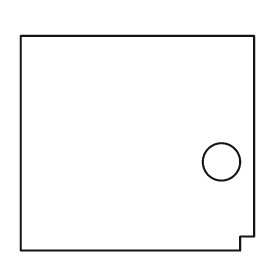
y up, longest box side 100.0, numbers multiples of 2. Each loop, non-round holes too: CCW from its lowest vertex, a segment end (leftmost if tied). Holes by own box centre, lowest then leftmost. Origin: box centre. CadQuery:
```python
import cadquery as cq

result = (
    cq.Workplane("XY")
    .moveTo(-50.0, -46.0)
    .lineTo(44.0, -46.0)
    .lineTo(44.0, -40.0)
    .lineTo(50.0, -40.0)
    .lineTo(50.0, 46.0)
    .lineTo(-50.0, 46.0)
    .close()
    .moveTo(36.0, -8.0)
    .circle(8.0)
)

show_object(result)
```